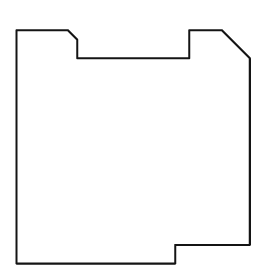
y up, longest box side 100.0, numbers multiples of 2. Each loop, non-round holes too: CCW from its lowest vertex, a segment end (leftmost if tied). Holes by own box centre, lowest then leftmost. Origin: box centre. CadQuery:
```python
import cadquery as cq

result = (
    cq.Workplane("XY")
    .moveTo(-50.0, -50.0)
    .lineTo(18.0, -50.0)
    .lineTo(18.0, -42.0)
    .lineTo(50.0, -42.0)
    .lineTo(50.0, 38.0)
    .lineTo(38.0, 50.0)
    .lineTo(24.0, 50.0)
    .lineTo(24.0, 38.0)
    .lineTo(-24.0, 38.0)
    .lineTo(-24.0, 46.0)
    .lineTo(-28.0, 50.0)
    .lineTo(-50.0, 50.0)
    .close()
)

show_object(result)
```